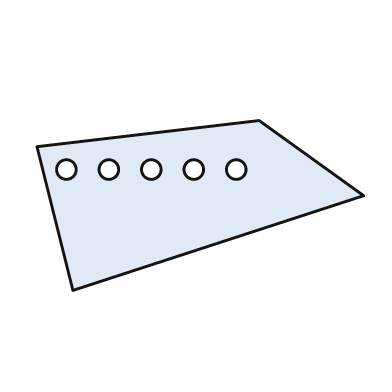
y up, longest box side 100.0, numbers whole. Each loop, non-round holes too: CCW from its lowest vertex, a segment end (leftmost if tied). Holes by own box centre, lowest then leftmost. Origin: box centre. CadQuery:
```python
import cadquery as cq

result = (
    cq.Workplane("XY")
    .moveTo(-39.0, -26.0)
    .lineTo(50.0, 3.0)
    .lineTo(18.0, 26.0)
    .lineTo(-50.0, 18.0)
    .close()
    .moveTo(-41.0, 11.0)
    .circle(3.0)
    .moveTo(-28.0, 11.0)
    .circle(3.0)
    .moveTo(-15.0, 11.0)
    .circle(3.0)
    .moveTo(-2.0, 11.0)
    .circle(3.0)
    .moveTo(11.0, 11.0)
    .circle(3.0)
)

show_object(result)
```